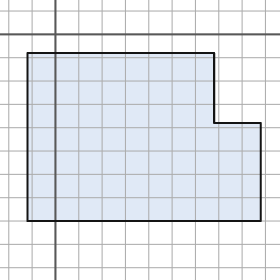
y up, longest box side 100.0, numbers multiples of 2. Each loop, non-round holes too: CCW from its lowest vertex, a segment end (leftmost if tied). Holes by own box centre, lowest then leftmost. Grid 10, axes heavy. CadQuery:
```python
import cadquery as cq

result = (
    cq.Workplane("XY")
    .moveTo(-12.0, -80.0)
    .lineTo(88.0, -80.0)
    .lineTo(88.0, -38.0)
    .lineTo(68.0, -38.0)
    .lineTo(68.0, -8.0)
    .lineTo(-12.0, -8.0)
    .close()
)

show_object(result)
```